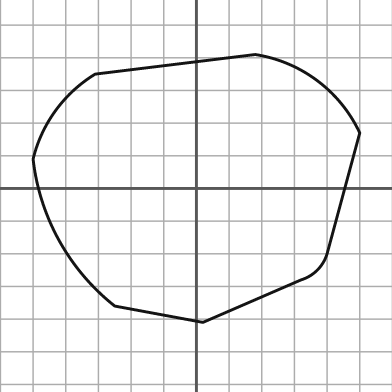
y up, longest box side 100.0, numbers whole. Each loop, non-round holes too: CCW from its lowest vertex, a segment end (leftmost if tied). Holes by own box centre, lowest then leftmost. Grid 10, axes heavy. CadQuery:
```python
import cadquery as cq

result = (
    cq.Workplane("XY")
    .moveTo(2.0, -41.0)
    .lineTo(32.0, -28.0)
    .threePointArc((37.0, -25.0), (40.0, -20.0))
    .lineTo(50.0, 17.0)
    .threePointArc((37.0, 33.0), (18.0, 41.0))
    .lineTo(-31.0, 35.0)
    .threePointArc((-43.0, 24.0), (-50.0, 9.0))
    .threePointArc((-42.0, -16.0), (-25.0, -36.0))
    .close()
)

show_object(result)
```